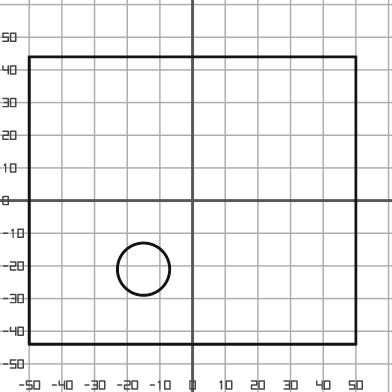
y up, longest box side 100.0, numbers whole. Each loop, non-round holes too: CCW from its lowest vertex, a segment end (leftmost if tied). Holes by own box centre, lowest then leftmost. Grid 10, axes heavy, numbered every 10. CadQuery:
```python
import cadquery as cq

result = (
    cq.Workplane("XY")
    .moveTo(-50.0, -44.0)
    .lineTo(50.0, -44.0)
    .lineTo(50.0, 44.0)
    .lineTo(-50.0, 44.0)
    .close()
    .moveTo(-15.0, -21.0)
    .circle(8.0)
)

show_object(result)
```